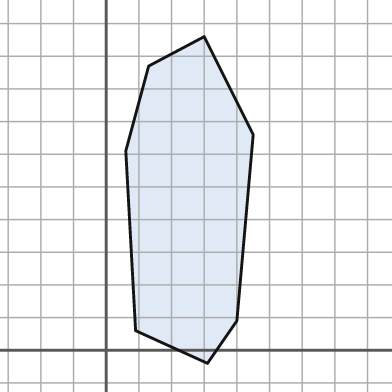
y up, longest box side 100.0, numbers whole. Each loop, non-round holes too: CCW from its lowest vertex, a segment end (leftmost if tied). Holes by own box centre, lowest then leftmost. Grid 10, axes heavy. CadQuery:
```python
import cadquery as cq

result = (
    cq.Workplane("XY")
    .moveTo(31.0, -4.0)
    .lineTo(40.0, 9.0)
    .lineTo(45.0, 66.0)
    .lineTo(30.0, 96.0)
    .lineTo(13.0, 87.0)
    .lineTo(6.0, 61.0)
    .lineTo(9.0, 6.0)
    .close()
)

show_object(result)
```